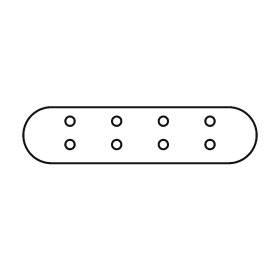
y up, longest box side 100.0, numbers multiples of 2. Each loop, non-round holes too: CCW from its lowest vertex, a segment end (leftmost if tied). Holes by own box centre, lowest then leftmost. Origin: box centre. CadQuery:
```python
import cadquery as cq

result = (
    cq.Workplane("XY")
    .moveTo(-38.0, -12.0)
    .lineTo(38.0, -12.0)
    .threePointArc((50.0, 0.0), (38.0, 12.0))
    .lineTo(-38.0, 12.0)
    .threePointArc((-50.0, 0.0), (-38.0, -12.0))
    .close()
    .moveTo(-30.0, -4.0)
    .circle(2.0)
    .moveTo(-10.0, -4.0)
    .circle(2.0)
    .moveTo(10.0, -4.0)
    .circle(2.0)
    .moveTo(30.0, -4.0)
    .circle(2.0)
    .moveTo(-30.0, 6.0)
    .circle(2.0)
    .moveTo(-10.0, 6.0)
    .circle(2.0)
    .moveTo(10.0, 6.0)
    .circle(2.0)
    .moveTo(30.0, 6.0)
    .circle(2.0)
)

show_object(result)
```